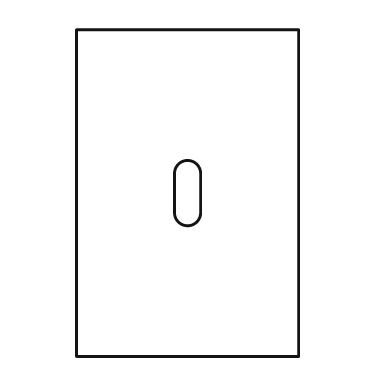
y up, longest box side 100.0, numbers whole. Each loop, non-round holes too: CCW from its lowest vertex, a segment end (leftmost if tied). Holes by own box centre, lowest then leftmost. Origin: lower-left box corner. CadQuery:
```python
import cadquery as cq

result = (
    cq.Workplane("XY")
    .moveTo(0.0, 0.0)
    .lineTo(68.0, 0.0)
    .lineTo(68.0, 100.0)
    .lineTo(0.0, 100.0)
    .close()
    .moveTo(30.0, 44.0)
    .threePointArc((34.0, 40.0), (38.0, 44.0))
    .lineTo(38.0, 56.0)
    .threePointArc((34.0, 60.0), (30.0, 56.0))
    .close()
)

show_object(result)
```